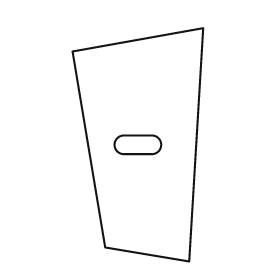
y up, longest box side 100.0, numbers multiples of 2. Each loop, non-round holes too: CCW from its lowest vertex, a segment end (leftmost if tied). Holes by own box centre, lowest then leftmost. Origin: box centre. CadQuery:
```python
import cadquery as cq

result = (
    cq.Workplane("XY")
    .moveTo(22.0, -50.0)
    .lineTo(28.0, 50.0)
    .lineTo(-28.0, 40.0)
    .lineTo(-14.0, -44.0)
    .close()
    .moveTo(-6.0, -4.0)
    .lineTo(6.0, -4.0)
    .threePointArc((10.0, 0.0), (6.0, 4.0))
    .lineTo(-6.0, 4.0)
    .threePointArc((-10.0, 0.0), (-6.0, -4.0))
    .close()
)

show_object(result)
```